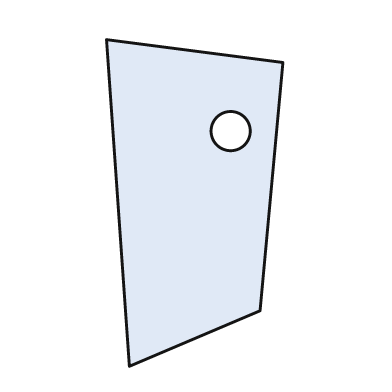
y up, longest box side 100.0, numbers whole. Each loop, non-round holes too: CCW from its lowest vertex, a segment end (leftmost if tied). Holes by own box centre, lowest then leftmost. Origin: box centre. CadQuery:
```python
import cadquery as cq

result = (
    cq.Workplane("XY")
    .moveTo(-20.0, -50.0)
    .lineTo(20.0, -33.0)
    .lineTo(27.0, 43.0)
    .lineTo(-27.0, 50.0)
    .close()
    .moveTo(11.0, 22.0)
    .circle(6.0)
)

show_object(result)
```